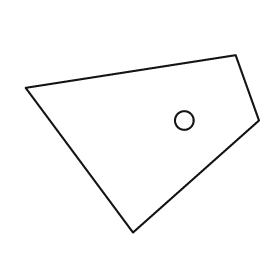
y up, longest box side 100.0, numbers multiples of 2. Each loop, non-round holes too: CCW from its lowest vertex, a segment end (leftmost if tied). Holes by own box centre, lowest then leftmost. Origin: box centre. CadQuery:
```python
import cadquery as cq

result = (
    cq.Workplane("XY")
    .moveTo(-4.0, -38.0)
    .lineTo(50.0, 10.0)
    .lineTo(40.0, 38.0)
    .lineTo(-50.0, 24.0)
    .close()
    .moveTo(18.0, 10.0)
    .circle(4.0)
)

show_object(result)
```